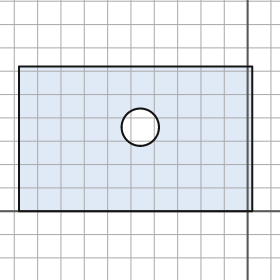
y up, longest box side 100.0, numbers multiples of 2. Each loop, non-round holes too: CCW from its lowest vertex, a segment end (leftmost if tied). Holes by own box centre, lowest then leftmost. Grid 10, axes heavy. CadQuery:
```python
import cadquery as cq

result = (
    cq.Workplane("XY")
    .moveTo(-98.0, 0.0)
    .lineTo(2.0, 0.0)
    .lineTo(2.0, 62.0)
    .lineTo(-98.0, 62.0)
    .close()
    .moveTo(-46.0, 36.0)
    .circle(8.0)
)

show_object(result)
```